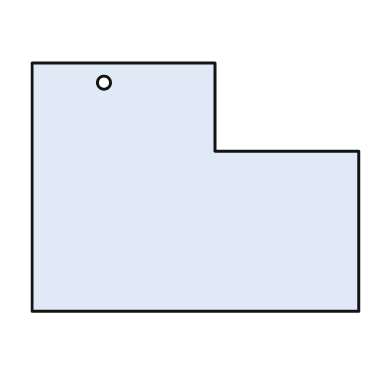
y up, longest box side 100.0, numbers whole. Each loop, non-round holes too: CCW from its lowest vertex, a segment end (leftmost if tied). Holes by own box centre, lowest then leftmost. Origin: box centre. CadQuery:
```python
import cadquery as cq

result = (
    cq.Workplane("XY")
    .moveTo(-50.0, -38.0)
    .lineTo(50.0, -38.0)
    .lineTo(50.0, 11.0)
    .lineTo(6.0, 11.0)
    .lineTo(6.0, 38.0)
    .lineTo(-50.0, 38.0)
    .close()
    .moveTo(-28.0, 32.0)
    .circle(2.0)
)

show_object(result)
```